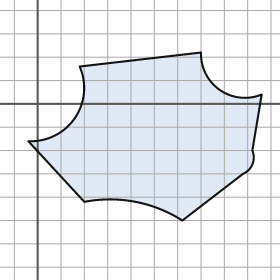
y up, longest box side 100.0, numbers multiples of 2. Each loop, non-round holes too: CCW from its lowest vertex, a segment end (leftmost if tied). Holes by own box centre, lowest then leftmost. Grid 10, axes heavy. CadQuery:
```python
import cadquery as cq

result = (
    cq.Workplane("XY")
    .moveTo(62.0, -50.0)
    .lineTo(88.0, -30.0)
    .threePointArc((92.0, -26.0), (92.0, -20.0))
    .lineTo(96.0, 4.0)
    .threePointArc((78.0, 6.0), (70.0, 22.0))
    .lineTo(18.0, 16.0)
    .threePointArc((16.0, -6.0), (-4.0, -16.0))
    .lineTo(20.0, -42.0)
    .threePointArc((42.0, -42.0), (62.0, -50.0))
    .close()
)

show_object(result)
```